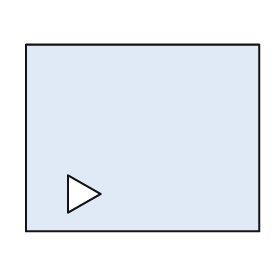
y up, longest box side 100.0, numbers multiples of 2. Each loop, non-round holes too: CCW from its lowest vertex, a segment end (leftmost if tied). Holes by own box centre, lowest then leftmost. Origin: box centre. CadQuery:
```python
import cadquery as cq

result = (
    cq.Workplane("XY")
    .moveTo(-50.0, -40.0)
    .lineTo(50.0, -40.0)
    .lineTo(50.0, 40.0)
    .lineTo(-50.0, 40.0)
    .close()
    .moveTo(-32.0, -32.0)
    .lineTo(-18.0, -24.0)
    .lineTo(-32.0, -16.0)
    .close()
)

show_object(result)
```